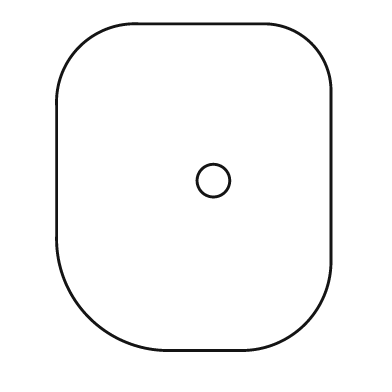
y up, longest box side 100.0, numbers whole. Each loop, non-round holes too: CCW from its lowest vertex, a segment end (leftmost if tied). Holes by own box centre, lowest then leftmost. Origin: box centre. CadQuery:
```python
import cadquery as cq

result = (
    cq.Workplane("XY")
    .moveTo(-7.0, -50.0)
    .lineTo(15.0, -50.0)
    .threePointArc((34.0, -42.0), (42.0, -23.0))
    .lineTo(42.0, 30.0)
    .threePointArc((36.0, 44.0), (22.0, 50.0))
    .lineTo(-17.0, 50.0)
    .threePointArc((-35.0, 43.0), (-42.0, 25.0))
    .lineTo(-42.0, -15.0)
    .threePointArc((-32.0, -40.0), (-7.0, -50.0))
    .close()
    .moveTo(6.0, 2.0)
    .circle(5.0)
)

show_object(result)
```